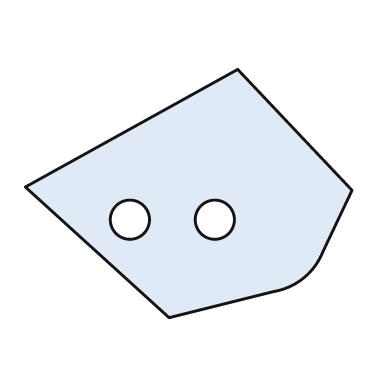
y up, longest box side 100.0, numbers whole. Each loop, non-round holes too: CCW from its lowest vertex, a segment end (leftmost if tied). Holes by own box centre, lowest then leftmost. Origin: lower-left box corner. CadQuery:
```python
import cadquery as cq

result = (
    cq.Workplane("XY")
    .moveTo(44.0, 0.0)
    .lineTo(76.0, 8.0)
    .threePointArc((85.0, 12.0), (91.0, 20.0))
    .lineTo(100.0, 39.0)
    .lineTo(65.0, 76.0)
    .lineTo(0.0, 40.0)
    .close()
    .moveTo(32.0, 30.0)
    .circle(6.0)
    .moveTo(58.0, 30.0)
    .circle(6.0)
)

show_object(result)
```